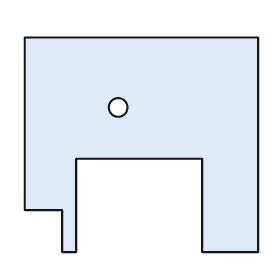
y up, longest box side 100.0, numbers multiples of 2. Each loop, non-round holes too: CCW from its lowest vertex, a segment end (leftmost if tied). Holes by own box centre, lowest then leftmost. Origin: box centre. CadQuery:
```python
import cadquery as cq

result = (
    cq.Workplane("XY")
    .moveTo(-34.0, -46.0)
    .lineTo(-28.0, -46.0)
    .lineTo(-28.0, -6.0)
    .lineTo(26.0, -6.0)
    .lineTo(26.0, -46.0)
    .lineTo(50.0, -46.0)
    .lineTo(50.0, 46.0)
    .lineTo(-50.0, 46.0)
    .lineTo(-50.0, -28.0)
    .lineTo(-34.0, -28.0)
    .close()
    .moveTo(-10.0, 16.0)
    .circle(4.0)
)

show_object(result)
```